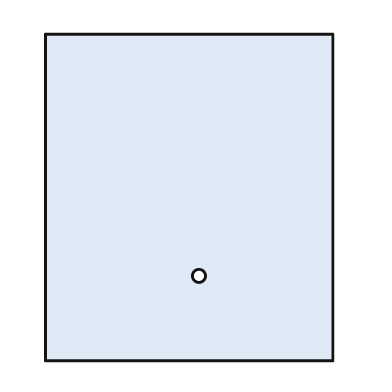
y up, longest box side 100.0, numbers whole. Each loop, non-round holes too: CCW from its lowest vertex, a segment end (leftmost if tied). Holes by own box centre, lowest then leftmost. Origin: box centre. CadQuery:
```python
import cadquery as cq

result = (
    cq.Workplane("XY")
    .moveTo(-44.0, -50.0)
    .lineTo(44.0, -50.0)
    .lineTo(44.0, 50.0)
    .lineTo(-44.0, 50.0)
    .close()
    .moveTo(3.0, -24.0)
    .circle(2.0)
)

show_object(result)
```